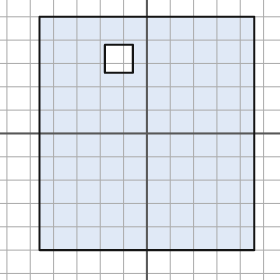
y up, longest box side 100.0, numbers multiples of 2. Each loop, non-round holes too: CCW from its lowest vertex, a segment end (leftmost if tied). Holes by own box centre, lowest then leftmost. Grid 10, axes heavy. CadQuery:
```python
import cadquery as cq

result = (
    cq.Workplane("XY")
    .moveTo(-46.0, -50.0)
    .lineTo(46.0, -50.0)
    .lineTo(46.0, 50.0)
    .lineTo(-46.0, 50.0)
    .close()
    .moveTo(-18.0, 26.0)
    .lineTo(-6.0, 26.0)
    .lineTo(-6.0, 38.0)
    .lineTo(-18.0, 38.0)
    .close()
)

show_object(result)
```